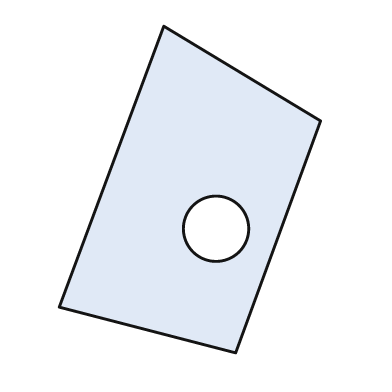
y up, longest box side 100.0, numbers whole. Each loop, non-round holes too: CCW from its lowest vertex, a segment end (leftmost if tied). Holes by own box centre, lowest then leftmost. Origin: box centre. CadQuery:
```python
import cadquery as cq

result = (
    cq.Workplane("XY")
    .moveTo(14.0, -50.0)
    .lineTo(40.0, 21.0)
    .lineTo(-8.0, 50.0)
    .lineTo(-40.0, -36.0)
    .close()
    .moveTo(8.0, -12.0)
    .circle(10.0)
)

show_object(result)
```